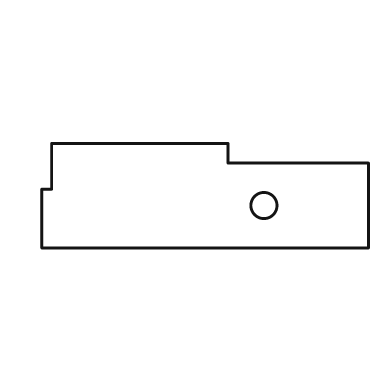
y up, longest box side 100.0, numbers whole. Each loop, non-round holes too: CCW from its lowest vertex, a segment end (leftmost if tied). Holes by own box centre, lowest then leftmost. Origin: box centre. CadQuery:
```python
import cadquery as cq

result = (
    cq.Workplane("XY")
    .moveTo(-50.0, -16.0)
    .lineTo(50.0, -16.0)
    .lineTo(50.0, 10.0)
    .lineTo(7.0, 10.0)
    .lineTo(7.0, 16.0)
    .lineTo(-47.0, 16.0)
    .lineTo(-47.0, 2.0)
    .lineTo(-50.0, 2.0)
    .close()
    .moveTo(18.0, -3.0)
    .circle(4.0)
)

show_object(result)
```